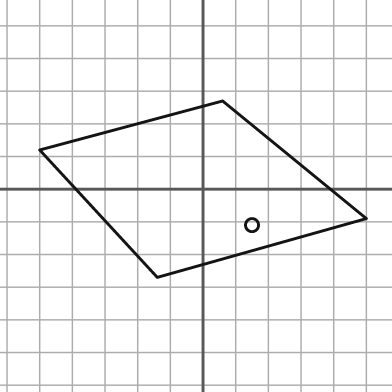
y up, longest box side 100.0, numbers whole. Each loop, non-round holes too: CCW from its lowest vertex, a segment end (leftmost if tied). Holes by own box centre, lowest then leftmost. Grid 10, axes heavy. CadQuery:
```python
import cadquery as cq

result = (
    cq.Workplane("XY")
    .moveTo(-14.0, -27.0)
    .lineTo(50.0, -9.0)
    .lineTo(6.0, 27.0)
    .lineTo(-50.0, 12.0)
    .close()
    .moveTo(15.0, -11.0)
    .circle(2.0)
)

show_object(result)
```